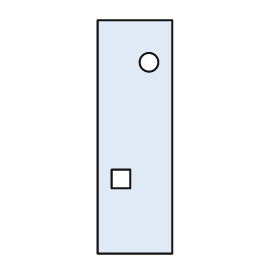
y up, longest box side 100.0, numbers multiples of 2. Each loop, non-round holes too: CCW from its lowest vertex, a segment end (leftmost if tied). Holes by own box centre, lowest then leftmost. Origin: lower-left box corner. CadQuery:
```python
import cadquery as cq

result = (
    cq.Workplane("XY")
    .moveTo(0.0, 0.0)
    .lineTo(32.0, 0.0)
    .lineTo(32.0, 100.0)
    .lineTo(0.0, 100.0)
    .close()
    .moveTo(6.0, 28.0)
    .lineTo(14.0, 28.0)
    .lineTo(14.0, 36.0)
    .lineTo(6.0, 36.0)
    .close()
    .moveTo(22.0, 82.0)
    .circle(4.0)
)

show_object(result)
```